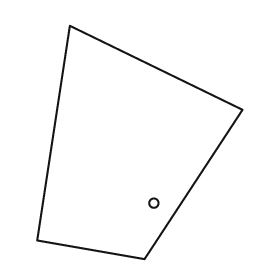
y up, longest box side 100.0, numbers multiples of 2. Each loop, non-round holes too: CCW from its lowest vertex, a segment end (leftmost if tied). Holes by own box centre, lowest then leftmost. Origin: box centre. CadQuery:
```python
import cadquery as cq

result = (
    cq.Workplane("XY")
    .moveTo(2.0, -50.0)
    .lineTo(44.0, 14.0)
    .lineTo(-30.0, 50.0)
    .lineTo(-44.0, -42.0)
    .close()
    .moveTo(6.0, -26.0)
    .circle(2.0)
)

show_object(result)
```